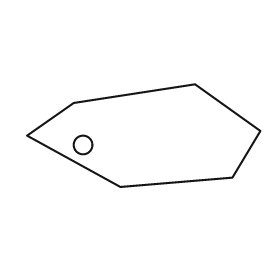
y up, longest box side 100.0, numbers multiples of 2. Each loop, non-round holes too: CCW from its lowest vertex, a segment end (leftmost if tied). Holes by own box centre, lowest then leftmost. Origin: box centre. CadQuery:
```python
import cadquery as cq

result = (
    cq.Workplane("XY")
    .moveTo(-10.0, -22.0)
    .lineTo(38.0, -18.0)
    .lineTo(50.0, 2.0)
    .lineTo(22.0, 22.0)
    .lineTo(-30.0, 14.0)
    .lineTo(-50.0, 0.0)
    .close()
    .moveTo(-26.0, -4.0)
    .circle(4.0)
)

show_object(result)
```